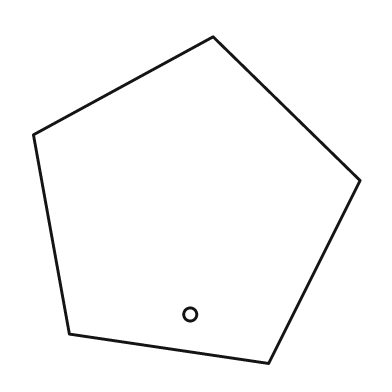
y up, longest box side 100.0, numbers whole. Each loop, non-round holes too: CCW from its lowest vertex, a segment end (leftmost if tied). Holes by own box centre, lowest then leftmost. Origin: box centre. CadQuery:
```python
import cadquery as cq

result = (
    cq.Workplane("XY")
    .moveTo(22.0, -50.0)
    .lineTo(50.0, 6.0)
    .lineTo(5.0, 50.0)
    .lineTo(-50.0, 20.0)
    .lineTo(-39.0, -41.0)
    .close()
    .moveTo(-2.0, -35.0)
    .circle(2.0)
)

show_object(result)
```